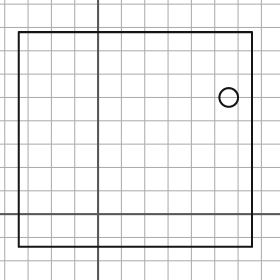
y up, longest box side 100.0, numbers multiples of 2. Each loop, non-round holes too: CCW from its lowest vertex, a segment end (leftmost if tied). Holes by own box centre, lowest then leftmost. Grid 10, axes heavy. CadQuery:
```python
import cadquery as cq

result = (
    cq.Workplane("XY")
    .moveTo(-34.0, -14.0)
    .lineTo(66.0, -14.0)
    .lineTo(66.0, 78.0)
    .lineTo(-34.0, 78.0)
    .close()
    .moveTo(56.0, 50.0)
    .circle(4.0)
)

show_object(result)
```